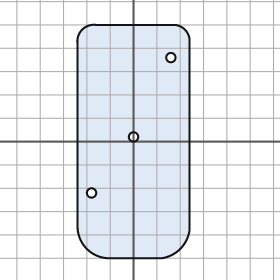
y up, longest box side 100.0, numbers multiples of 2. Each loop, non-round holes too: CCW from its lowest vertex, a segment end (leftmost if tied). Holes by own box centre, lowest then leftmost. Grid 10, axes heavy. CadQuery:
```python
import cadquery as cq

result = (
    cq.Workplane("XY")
    .moveTo(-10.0, -50.0)
    .lineTo(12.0, -50.0)
    .threePointArc((20.0, -46.0), (24.0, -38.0))
    .lineTo(24.0, 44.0)
    .threePointArc((22.0, 48.0), (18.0, 50.0))
    .lineTo(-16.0, 50.0)
    .threePointArc((-22.0, 48.0), (-24.0, 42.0))
    .lineTo(-24.0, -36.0)
    .threePointArc((-20.0, -46.0), (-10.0, -50.0))
    .close()
    .moveTo(-18.0, -22.0)
    .circle(2.0)
    .moveTo(0.0, 2.0)
    .circle(2.0)
    .moveTo(16.0, 36.0)
    .circle(2.0)
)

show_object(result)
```